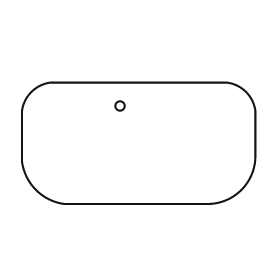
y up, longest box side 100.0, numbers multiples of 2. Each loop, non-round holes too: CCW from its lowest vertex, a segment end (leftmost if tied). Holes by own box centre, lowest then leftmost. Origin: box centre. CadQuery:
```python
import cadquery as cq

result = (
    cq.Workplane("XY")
    .moveTo(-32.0, -26.0)
    .lineTo(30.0, -26.0)
    .threePointArc((44.0, -20.0), (50.0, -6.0))
    .lineTo(50.0, 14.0)
    .threePointArc((46.0, 22.0), (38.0, 26.0))
    .lineTo(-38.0, 26.0)
    .threePointArc((-46.0, 22.0), (-50.0, 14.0))
    .lineTo(-50.0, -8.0)
    .threePointArc((-44.0, -20.0), (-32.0, -26.0))
    .close()
    .moveTo(-8.0, 16.0)
    .circle(2.0)
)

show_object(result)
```